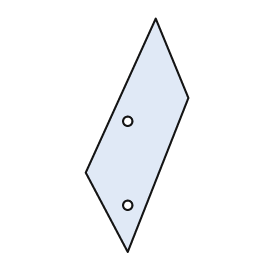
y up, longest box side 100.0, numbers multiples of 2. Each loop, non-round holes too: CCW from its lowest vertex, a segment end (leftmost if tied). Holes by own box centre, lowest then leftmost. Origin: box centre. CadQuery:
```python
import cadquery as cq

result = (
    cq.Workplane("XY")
    .moveTo(-4.0, -50.0)
    .lineTo(22.0, 16.0)
    .lineTo(8.0, 50.0)
    .lineTo(-22.0, -16.0)
    .close()
    .moveTo(-4.0, -30.0)
    .circle(2.0)
    .moveTo(-4.0, 6.0)
    .circle(2.0)
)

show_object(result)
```